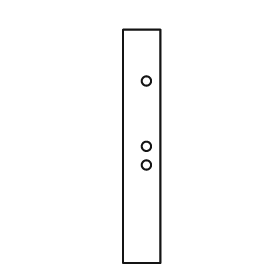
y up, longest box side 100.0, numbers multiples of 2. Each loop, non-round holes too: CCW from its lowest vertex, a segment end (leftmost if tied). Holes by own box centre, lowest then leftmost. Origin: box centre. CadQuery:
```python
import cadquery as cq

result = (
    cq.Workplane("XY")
    .moveTo(-8.0, -50.0)
    .lineTo(8.0, -50.0)
    .lineTo(8.0, 50.0)
    .lineTo(-8.0, 50.0)
    .close()
    .moveTo(2.0, -8.0)
    .circle(2.0)
    .moveTo(2.0, 0.0)
    .circle(2.0)
    .moveTo(2.0, 28.0)
    .circle(2.0)
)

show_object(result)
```